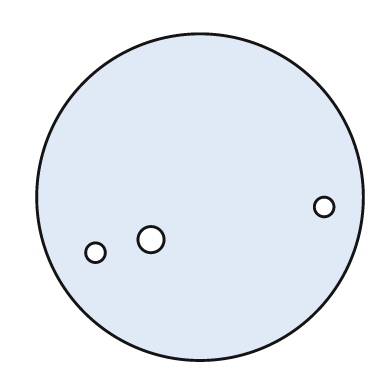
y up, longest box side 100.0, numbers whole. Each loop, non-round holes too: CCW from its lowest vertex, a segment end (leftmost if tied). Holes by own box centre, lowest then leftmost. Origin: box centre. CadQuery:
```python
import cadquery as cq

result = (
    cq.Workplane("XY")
    .moveTo(0.0, 0.0)
    .circle(50.0)
    .moveTo(-32.0, -17.0)
    .circle(3.0)
    .moveTo(-15.0, -13.0)
    .circle(4.0)
    .moveTo(38.0, -3.0)
    .circle(3.0)
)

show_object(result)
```